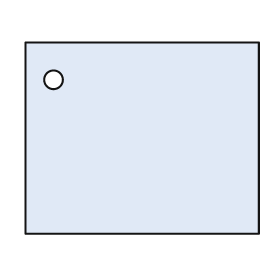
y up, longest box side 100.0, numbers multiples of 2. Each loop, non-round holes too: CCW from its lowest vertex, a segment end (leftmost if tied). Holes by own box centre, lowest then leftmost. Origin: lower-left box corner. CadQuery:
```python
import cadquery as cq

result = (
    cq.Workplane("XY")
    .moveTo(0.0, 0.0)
    .lineTo(100.0, 0.0)
    .lineTo(100.0, 82.0)
    .lineTo(0.0, 82.0)
    .close()
    .moveTo(12.0, 66.0)
    .circle(4.0)
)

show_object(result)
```